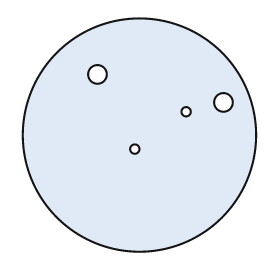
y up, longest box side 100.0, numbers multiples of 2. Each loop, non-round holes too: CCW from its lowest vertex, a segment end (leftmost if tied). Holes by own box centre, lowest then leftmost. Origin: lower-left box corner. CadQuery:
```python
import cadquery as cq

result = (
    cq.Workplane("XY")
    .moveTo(50.0, 50.0)
    .circle(50.0)
    .moveTo(48.0, 44.0)
    .circle(2.0)
    .moveTo(70.0, 60.0)
    .circle(2.0)
    .moveTo(86.0, 64.0)
    .circle(4.0)
    .moveTo(32.0, 76.0)
    .circle(4.0)
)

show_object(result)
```